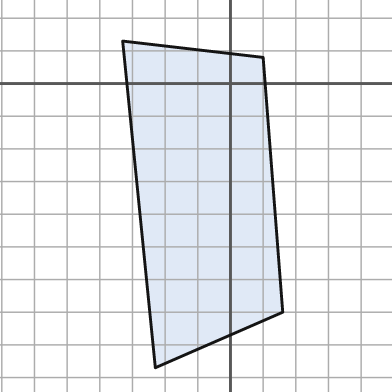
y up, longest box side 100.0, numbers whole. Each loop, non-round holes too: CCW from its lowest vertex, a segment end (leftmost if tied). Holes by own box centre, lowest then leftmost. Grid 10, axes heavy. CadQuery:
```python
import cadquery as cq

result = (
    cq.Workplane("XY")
    .moveTo(-23.0, -87.0)
    .lineTo(16.0, -70.0)
    .lineTo(10.0, 8.0)
    .lineTo(-33.0, 13.0)
    .close()
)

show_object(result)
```